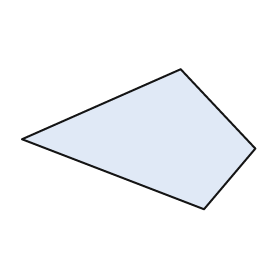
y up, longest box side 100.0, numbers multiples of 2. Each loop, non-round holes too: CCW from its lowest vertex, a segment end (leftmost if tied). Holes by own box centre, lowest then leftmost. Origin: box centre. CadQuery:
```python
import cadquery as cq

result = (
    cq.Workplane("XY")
    .moveTo(28.0, -30.0)
    .lineTo(50.0, -4.0)
    .lineTo(18.0, 30.0)
    .lineTo(-50.0, 0.0)
    .close()
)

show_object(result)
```